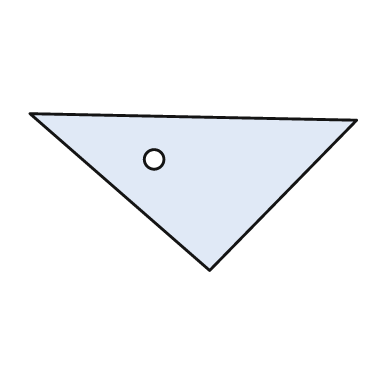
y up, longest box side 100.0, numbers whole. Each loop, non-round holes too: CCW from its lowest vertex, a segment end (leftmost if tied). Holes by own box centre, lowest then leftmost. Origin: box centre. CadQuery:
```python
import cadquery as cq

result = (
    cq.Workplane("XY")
    .moveTo(5.0, -24.0)
    .lineTo(50.0, 22.0)
    .lineTo(-50.0, 24.0)
    .close()
    .moveTo(-12.0, 10.0)
    .circle(3.0)
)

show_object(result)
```